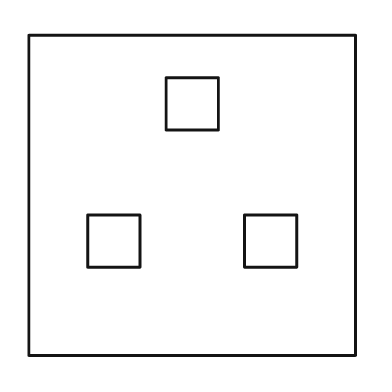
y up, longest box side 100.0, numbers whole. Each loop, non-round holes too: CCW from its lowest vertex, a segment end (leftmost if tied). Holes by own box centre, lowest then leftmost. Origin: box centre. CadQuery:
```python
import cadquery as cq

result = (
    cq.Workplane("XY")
    .moveTo(-50.0, -49.0)
    .lineTo(50.0, -49.0)
    .lineTo(50.0, 49.0)
    .lineTo(-50.0, 49.0)
    .close()
    .moveTo(-32.0, -22.0)
    .lineTo(-16.0, -22.0)
    .lineTo(-16.0, -6.0)
    .lineTo(-32.0, -6.0)
    .close()
    .moveTo(16.0, -22.0)
    .lineTo(32.0, -22.0)
    .lineTo(32.0, -6.0)
    .lineTo(16.0, -6.0)
    .close()
    .moveTo(-8.0, 20.0)
    .lineTo(8.0, 20.0)
    .lineTo(8.0, 36.0)
    .lineTo(-8.0, 36.0)
    .close()
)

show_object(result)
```